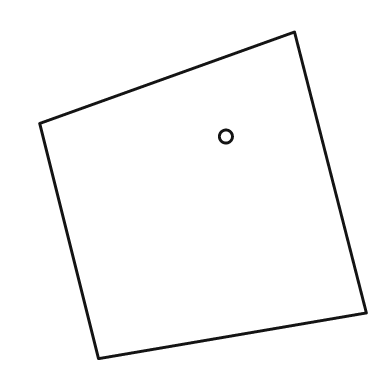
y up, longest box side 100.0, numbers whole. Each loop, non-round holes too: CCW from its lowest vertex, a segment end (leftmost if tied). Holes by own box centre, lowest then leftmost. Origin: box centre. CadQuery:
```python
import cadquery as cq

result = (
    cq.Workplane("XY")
    .moveTo(-32.0, -50.0)
    .lineTo(50.0, -36.0)
    .lineTo(28.0, 50.0)
    .lineTo(-50.0, 22.0)
    .close()
    .moveTo(7.0, 18.0)
    .circle(2.0)
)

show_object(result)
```